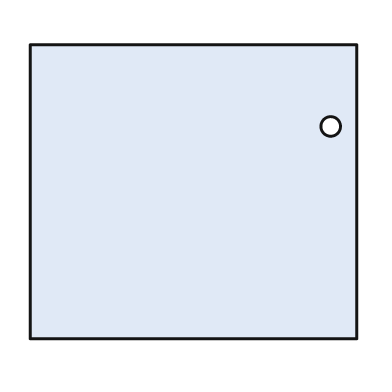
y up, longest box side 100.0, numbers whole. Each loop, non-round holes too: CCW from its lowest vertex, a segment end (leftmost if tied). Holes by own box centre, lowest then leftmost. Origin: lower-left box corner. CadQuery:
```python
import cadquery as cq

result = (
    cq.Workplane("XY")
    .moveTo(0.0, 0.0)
    .lineTo(100.0, 0.0)
    .lineTo(100.0, 90.0)
    .lineTo(0.0, 90.0)
    .close()
    .moveTo(92.0, 65.0)
    .circle(3.0)
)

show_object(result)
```